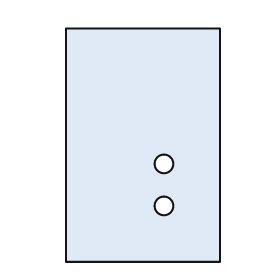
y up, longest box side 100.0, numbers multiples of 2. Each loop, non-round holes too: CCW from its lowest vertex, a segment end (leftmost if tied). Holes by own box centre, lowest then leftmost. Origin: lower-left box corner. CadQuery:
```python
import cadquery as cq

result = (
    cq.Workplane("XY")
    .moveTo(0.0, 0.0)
    .lineTo(66.0, 0.0)
    .lineTo(66.0, 100.0)
    .lineTo(0.0, 100.0)
    .close()
    .moveTo(42.0, 24.0)
    .circle(4.0)
    .moveTo(42.0, 42.0)
    .circle(4.0)
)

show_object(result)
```